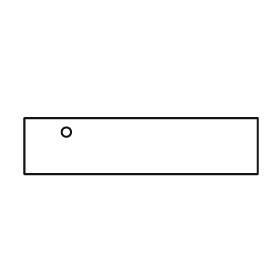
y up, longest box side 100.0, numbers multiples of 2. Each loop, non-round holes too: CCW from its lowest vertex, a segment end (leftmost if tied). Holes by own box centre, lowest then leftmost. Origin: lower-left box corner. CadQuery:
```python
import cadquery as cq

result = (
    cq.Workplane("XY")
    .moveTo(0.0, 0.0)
    .lineTo(100.0, 0.0)
    .lineTo(100.0, 24.0)
    .lineTo(0.0, 24.0)
    .close()
    .moveTo(18.0, 18.0)
    .circle(2.0)
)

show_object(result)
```